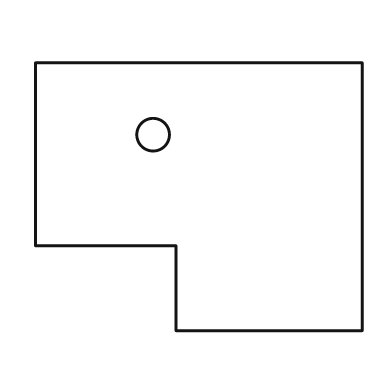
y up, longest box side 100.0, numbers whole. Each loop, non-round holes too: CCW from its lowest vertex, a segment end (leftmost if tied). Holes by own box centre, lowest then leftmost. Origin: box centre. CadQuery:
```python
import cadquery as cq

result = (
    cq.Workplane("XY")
    .moveTo(-7.0, -41.0)
    .lineTo(50.0, -41.0)
    .lineTo(50.0, 41.0)
    .lineTo(-50.0, 41.0)
    .lineTo(-50.0, -15.0)
    .lineTo(-7.0, -15.0)
    .close()
    .moveTo(-14.0, 19.0)
    .circle(5.0)
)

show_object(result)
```